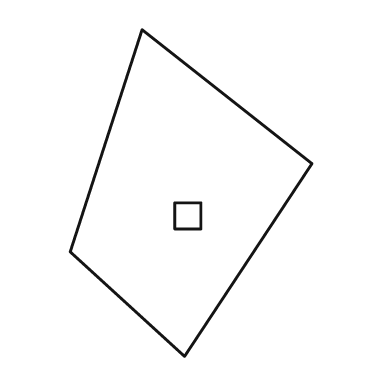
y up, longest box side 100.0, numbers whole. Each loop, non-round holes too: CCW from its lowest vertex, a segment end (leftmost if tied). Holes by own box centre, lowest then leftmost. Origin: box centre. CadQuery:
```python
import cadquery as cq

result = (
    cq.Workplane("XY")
    .moveTo(-2.0, -50.0)
    .lineTo(37.0, 9.0)
    .lineTo(-15.0, 50.0)
    .lineTo(-37.0, -18.0)
    .close()
    .moveTo(-5.0, -11.0)
    .lineTo(3.0, -11.0)
    .lineTo(3.0, -3.0)
    .lineTo(-5.0, -3.0)
    .close()
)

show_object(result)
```